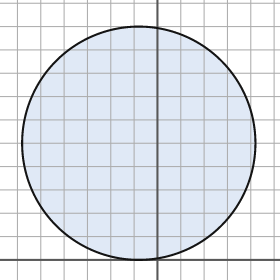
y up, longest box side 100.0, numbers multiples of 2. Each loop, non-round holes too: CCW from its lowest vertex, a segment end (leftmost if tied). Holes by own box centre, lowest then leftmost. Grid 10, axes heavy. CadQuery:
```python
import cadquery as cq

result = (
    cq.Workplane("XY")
    .moveTo(-8.0, 50.0)
    .circle(50.0)
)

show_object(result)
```